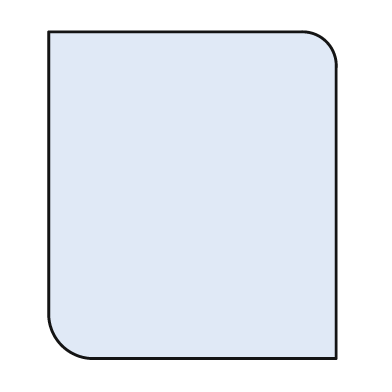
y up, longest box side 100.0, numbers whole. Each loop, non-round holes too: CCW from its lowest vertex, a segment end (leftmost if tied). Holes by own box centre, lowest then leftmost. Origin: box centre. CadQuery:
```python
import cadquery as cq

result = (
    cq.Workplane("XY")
    .moveTo(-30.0, -50.0)
    .lineTo(44.0, -50.0)
    .lineTo(44.0, 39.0)
    .threePointArc((41.0, 47.0), (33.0, 50.0))
    .lineTo(-44.0, 50.0)
    .lineTo(-44.0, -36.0)
    .threePointArc((-40.0, -46.0), (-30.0, -50.0))
    .close()
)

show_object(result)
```